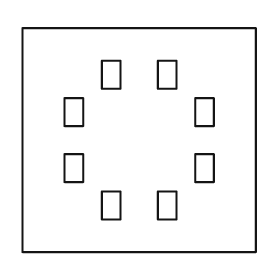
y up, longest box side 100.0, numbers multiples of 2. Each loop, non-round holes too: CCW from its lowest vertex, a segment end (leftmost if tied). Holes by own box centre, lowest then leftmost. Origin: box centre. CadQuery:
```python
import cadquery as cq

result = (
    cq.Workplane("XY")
    .moveTo(-50.0, -48.0)
    .lineTo(50.0, -48.0)
    .lineTo(50.0, 48.0)
    .lineTo(-50.0, 48.0)
    .close()
    .moveTo(-16.0, -34.0)
    .lineTo(-8.0, -34.0)
    .lineTo(-8.0, -22.0)
    .lineTo(-16.0, -22.0)
    .close()
    .moveTo(8.0, -34.0)
    .lineTo(16.0, -34.0)
    .lineTo(16.0, -22.0)
    .lineTo(8.0, -22.0)
    .close()
    .moveTo(-32.0, -18.0)
    .lineTo(-24.0, -18.0)
    .lineTo(-24.0, -6.0)
    .lineTo(-32.0, -6.0)
    .close()
    .moveTo(24.0, -18.0)
    .lineTo(32.0, -18.0)
    .lineTo(32.0, -6.0)
    .lineTo(24.0, -6.0)
    .close()
    .moveTo(-32.0, 6.0)
    .lineTo(-24.0, 6.0)
    .lineTo(-24.0, 18.0)
    .lineTo(-32.0, 18.0)
    .close()
    .moveTo(24.0, 6.0)
    .lineTo(32.0, 6.0)
    .lineTo(32.0, 18.0)
    .lineTo(24.0, 18.0)
    .close()
    .moveTo(-16.0, 22.0)
    .lineTo(-8.0, 22.0)
    .lineTo(-8.0, 34.0)
    .lineTo(-16.0, 34.0)
    .close()
    .moveTo(8.0, 22.0)
    .lineTo(16.0, 22.0)
    .lineTo(16.0, 34.0)
    .lineTo(8.0, 34.0)
    .close()
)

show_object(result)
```